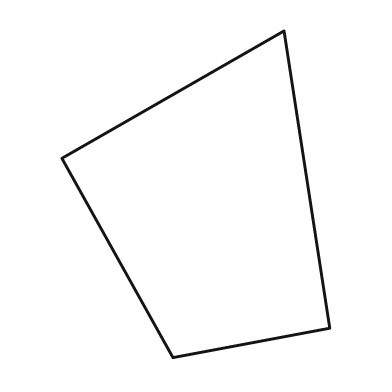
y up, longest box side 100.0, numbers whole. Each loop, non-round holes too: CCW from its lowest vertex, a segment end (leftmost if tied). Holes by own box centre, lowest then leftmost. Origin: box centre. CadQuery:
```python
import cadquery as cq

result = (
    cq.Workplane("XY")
    .moveTo(-7.0, -50.0)
    .lineTo(41.0, -41.0)
    .lineTo(27.0, 50.0)
    .lineTo(-41.0, 11.0)
    .close()
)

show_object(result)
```